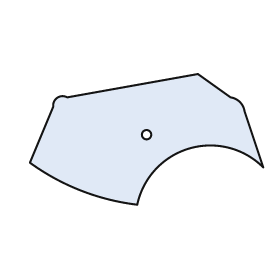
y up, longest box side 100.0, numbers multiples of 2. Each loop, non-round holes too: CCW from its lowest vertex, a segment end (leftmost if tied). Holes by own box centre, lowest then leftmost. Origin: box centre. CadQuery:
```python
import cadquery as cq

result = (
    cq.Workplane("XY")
    .moveTo(-4.0, -28.0)
    .threePointArc((18.0, -4.0), (50.0, -12.0))
    .lineTo(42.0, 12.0)
    .threePointArc((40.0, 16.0), (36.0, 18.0))
    .lineTo(22.0, 28.0)
    .lineTo(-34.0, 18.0)
    .threePointArc((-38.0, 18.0), (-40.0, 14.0))
    .lineTo(-50.0, -10.0)
    .threePointArc((-28.0, -22.0), (-4.0, -28.0))
    .close()
    .moveTo(0.0, 2.0)
    .circle(2.0)
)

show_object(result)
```